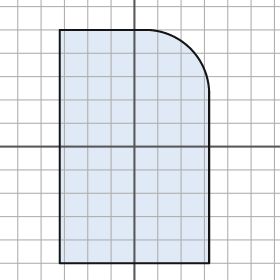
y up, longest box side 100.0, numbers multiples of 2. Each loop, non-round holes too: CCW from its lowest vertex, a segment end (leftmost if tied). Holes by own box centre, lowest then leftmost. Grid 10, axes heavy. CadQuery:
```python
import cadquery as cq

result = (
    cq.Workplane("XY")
    .moveTo(-32.0, -50.0)
    .lineTo(32.0, -50.0)
    .lineTo(32.0, 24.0)
    .threePointArc((24.0, 42.0), (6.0, 50.0))
    .lineTo(-32.0, 50.0)
    .close()
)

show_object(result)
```